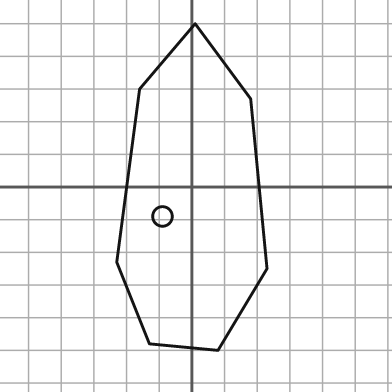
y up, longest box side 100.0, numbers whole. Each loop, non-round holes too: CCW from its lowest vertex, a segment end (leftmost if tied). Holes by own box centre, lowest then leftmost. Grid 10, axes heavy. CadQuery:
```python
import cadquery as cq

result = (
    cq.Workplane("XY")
    .moveTo(8.0, -50.0)
    .lineTo(23.0, -25.0)
    .lineTo(18.0, 27.0)
    .lineTo(1.0, 50.0)
    .lineTo(-16.0, 30.0)
    .lineTo(-23.0, -23.0)
    .lineTo(-13.0, -48.0)
    .close()
    .moveTo(-9.0, -9.0)
    .circle(3.0)
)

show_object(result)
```